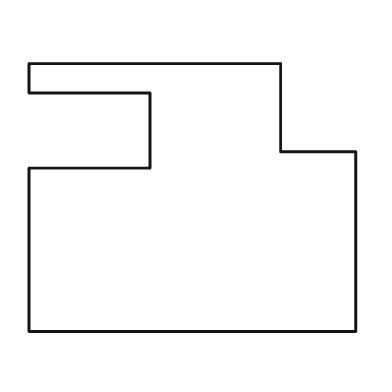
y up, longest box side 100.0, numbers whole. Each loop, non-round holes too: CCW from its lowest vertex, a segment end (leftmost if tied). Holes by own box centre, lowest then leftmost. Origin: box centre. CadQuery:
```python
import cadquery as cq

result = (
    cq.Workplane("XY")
    .moveTo(-50.0, -41.0)
    .lineTo(50.0, -41.0)
    .lineTo(50.0, 14.0)
    .lineTo(27.0, 14.0)
    .lineTo(27.0, 41.0)
    .lineTo(-50.0, 41.0)
    .lineTo(-50.0, 32.0)
    .lineTo(-13.0, 32.0)
    .lineTo(-13.0, 9.0)
    .lineTo(-50.0, 9.0)
    .close()
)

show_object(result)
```